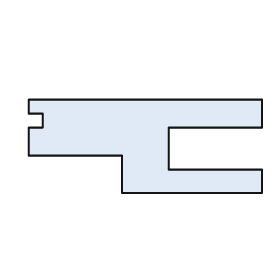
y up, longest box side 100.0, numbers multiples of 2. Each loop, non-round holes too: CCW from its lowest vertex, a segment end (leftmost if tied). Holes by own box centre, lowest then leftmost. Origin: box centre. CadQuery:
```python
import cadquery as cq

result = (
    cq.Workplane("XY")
    .moveTo(-10.0, -20.0)
    .lineTo(50.0, -20.0)
    .lineTo(50.0, -10.0)
    .lineTo(10.0, -10.0)
    .lineTo(10.0, 8.0)
    .lineTo(50.0, 8.0)
    .lineTo(50.0, 20.0)
    .lineTo(-50.0, 20.0)
    .lineTo(-50.0, 14.0)
    .lineTo(-44.0, 14.0)
    .lineTo(-44.0, 8.0)
    .lineTo(-50.0, 8.0)
    .lineTo(-50.0, -4.0)
    .lineTo(-10.0, -4.0)
    .close()
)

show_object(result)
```